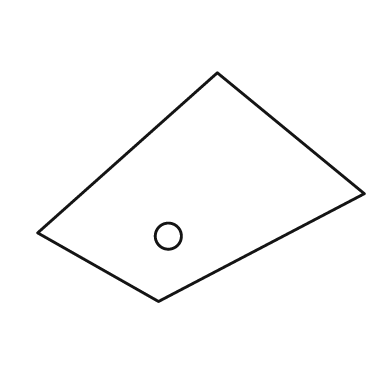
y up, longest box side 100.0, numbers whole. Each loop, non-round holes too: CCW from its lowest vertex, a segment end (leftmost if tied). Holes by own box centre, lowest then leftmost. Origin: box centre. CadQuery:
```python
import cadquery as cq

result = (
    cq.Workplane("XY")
    .moveTo(-13.0, -35.0)
    .lineTo(50.0, -2.0)
    .lineTo(5.0, 35.0)
    .lineTo(-50.0, -14.0)
    .close()
    .moveTo(-10.0, -15.0)
    .circle(4.0)
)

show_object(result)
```